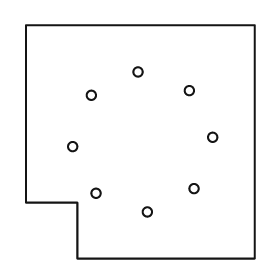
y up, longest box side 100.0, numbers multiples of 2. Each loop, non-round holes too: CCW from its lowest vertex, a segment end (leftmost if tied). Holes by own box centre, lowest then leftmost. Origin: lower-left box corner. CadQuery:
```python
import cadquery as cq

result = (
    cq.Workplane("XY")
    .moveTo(22.0, 0.0)
    .lineTo(98.0, 0.0)
    .lineTo(98.0, 100.0)
    .lineTo(0.0, 100.0)
    .lineTo(0.0, 24.0)
    .lineTo(22.0, 24.0)
    .close()
    .moveTo(52.0, 20.0)
    .circle(2.0)
    .moveTo(30.0, 28.0)
    .circle(2.0)
    .moveTo(72.0, 30.0)
    .circle(2.0)
    .moveTo(20.0, 48.0)
    .circle(2.0)
    .moveTo(80.0, 52.0)
    .circle(2.0)
    .moveTo(28.0, 70.0)
    .circle(2.0)
    .moveTo(70.0, 72.0)
    .circle(2.0)
    .moveTo(48.0, 80.0)
    .circle(2.0)
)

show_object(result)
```